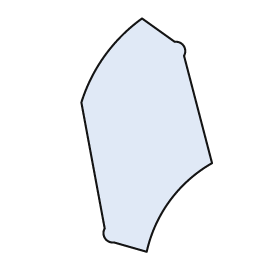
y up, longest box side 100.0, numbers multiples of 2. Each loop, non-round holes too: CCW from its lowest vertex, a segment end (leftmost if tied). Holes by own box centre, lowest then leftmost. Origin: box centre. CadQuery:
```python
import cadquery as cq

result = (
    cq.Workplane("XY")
    .moveTo(0.0, -50.0)
    .threePointArc((10.0, -28.0), (28.0, -12.0))
    .lineTo(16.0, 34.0)
    .threePointArc((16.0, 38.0), (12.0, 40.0))
    .lineTo(-2.0, 50.0)
    .threePointArc((-18.0, 34.0), (-28.0, 14.0))
    .lineTo(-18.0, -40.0)
    .threePointArc((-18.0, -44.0), (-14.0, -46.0))
    .close()
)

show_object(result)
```